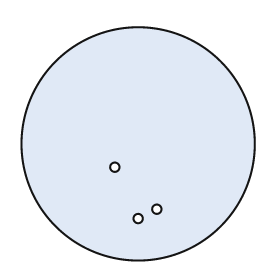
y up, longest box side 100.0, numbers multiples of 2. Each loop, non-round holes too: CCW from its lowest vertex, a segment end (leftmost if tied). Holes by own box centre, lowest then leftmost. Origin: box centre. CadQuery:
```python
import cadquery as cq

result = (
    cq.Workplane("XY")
    .moveTo(0.0, 0.0)
    .circle(50.0)
    .moveTo(0.0, -32.0)
    .circle(2.0)
    .moveTo(8.0, -28.0)
    .circle(2.0)
    .moveTo(-10.0, -10.0)
    .circle(2.0)
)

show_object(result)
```